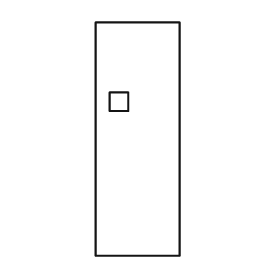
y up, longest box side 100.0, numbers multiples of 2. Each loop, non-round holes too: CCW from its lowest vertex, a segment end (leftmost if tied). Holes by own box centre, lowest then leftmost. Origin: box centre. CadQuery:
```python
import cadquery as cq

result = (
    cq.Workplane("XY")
    .moveTo(-18.0, -50.0)
    .lineTo(18.0, -50.0)
    .lineTo(18.0, 50.0)
    .lineTo(-18.0, 50.0)
    .close()
    .moveTo(-12.0, 12.0)
    .lineTo(-4.0, 12.0)
    .lineTo(-4.0, 20.0)
    .lineTo(-12.0, 20.0)
    .close()
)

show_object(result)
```